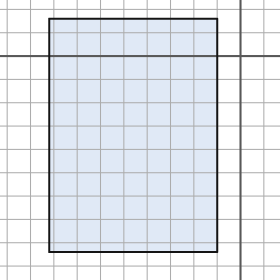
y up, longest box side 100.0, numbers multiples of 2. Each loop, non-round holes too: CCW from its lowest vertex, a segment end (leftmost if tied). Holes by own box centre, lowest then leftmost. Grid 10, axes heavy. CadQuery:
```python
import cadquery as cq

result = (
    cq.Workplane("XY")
    .moveTo(-82.0, -84.0)
    .lineTo(-10.0, -84.0)
    .lineTo(-10.0, 16.0)
    .lineTo(-82.0, 16.0)
    .close()
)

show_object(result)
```